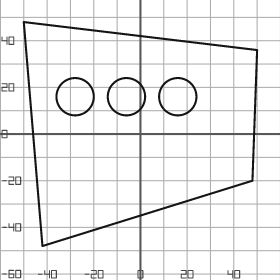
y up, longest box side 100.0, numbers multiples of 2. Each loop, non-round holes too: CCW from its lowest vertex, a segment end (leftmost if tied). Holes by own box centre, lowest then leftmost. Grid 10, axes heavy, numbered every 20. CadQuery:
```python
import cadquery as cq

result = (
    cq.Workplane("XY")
    .moveTo(-42.0, -48.0)
    .lineTo(48.0, -20.0)
    .lineTo(50.0, 36.0)
    .lineTo(-50.0, 48.0)
    .close()
    .moveTo(-28.0, 16.0)
    .circle(8.0)
    .moveTo(-6.0, 16.0)
    .circle(8.0)
    .moveTo(16.0, 16.0)
    .circle(8.0)
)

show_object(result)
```